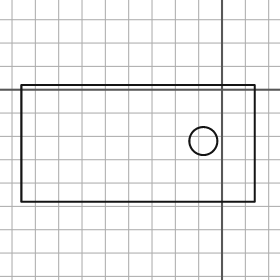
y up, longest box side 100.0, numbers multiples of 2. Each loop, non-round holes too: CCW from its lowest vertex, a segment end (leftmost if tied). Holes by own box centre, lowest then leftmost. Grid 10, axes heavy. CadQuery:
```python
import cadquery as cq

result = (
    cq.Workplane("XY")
    .moveTo(-86.0, -48.0)
    .lineTo(14.0, -48.0)
    .lineTo(14.0, 2.0)
    .lineTo(-86.0, 2.0)
    .close()
    .moveTo(-8.0, -22.0)
    .circle(6.0)
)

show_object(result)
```